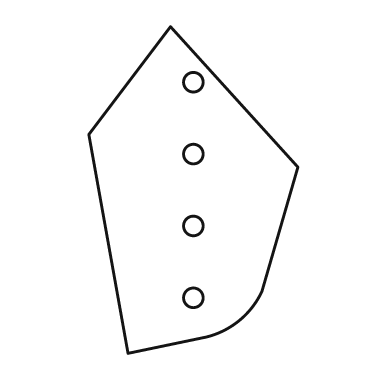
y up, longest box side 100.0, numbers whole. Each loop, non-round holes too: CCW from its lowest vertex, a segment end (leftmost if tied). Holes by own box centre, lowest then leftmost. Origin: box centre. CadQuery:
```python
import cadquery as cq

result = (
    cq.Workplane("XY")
    .moveTo(-20.0, -50.0)
    .lineTo(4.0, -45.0)
    .threePointArc((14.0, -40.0), (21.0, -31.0))
    .lineTo(32.0, 7.0)
    .lineTo(-7.0, 50.0)
    .lineTo(-32.0, 17.0)
    .close()
    .moveTo(0.0, -33.0)
    .circle(3.0)
    .moveTo(0.0, -11.0)
    .circle(3.0)
    .moveTo(0.0, 11.0)
    .circle(3.0)
    .moveTo(0.0, 33.0)
    .circle(3.0)
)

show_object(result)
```